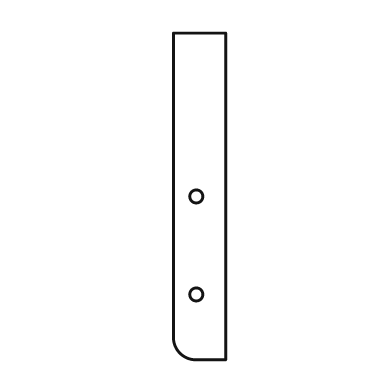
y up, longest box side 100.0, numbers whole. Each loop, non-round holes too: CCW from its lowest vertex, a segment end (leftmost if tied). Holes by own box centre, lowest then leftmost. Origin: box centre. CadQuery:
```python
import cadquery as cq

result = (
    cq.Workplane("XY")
    .moveTo(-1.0, -50.0)
    .lineTo(8.0, -50.0)
    .lineTo(8.0, 50.0)
    .lineTo(-8.0, 50.0)
    .lineTo(-8.0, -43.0)
    .threePointArc((-6.0, -48.0), (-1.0, -50.0))
    .close()
    .moveTo(-1.0, -30.0)
    .circle(2.0)
    .moveTo(-1.0, 0.0)
    .circle(2.0)
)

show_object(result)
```